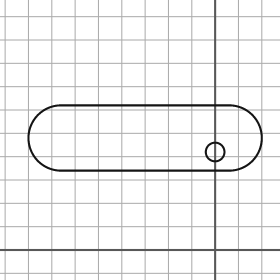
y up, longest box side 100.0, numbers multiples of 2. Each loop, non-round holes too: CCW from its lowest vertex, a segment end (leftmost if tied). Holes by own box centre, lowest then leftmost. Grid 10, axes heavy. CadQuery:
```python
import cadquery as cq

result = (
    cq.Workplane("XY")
    .moveTo(-66.0, 34.0)
    .lineTo(6.0, 34.0)
    .threePointArc((20.0, 48.0), (6.0, 62.0))
    .lineTo(-66.0, 62.0)
    .threePointArc((-80.0, 48.0), (-66.0, 34.0))
    .close()
    .moveTo(0.0, 42.0)
    .circle(4.0)
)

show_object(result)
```